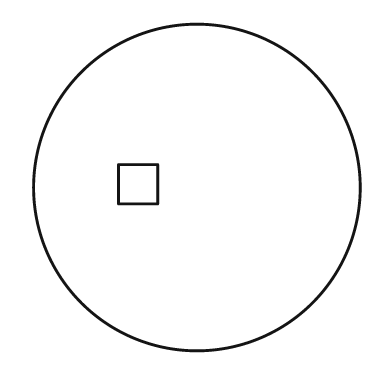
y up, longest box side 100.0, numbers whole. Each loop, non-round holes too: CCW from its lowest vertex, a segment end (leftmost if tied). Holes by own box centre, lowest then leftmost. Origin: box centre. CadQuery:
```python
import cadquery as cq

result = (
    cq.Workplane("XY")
    .moveTo(0.0, 0.0)
    .circle(50.0)
    .moveTo(-24.0, -5.0)
    .lineTo(-12.0, -5.0)
    .lineTo(-12.0, 7.0)
    .lineTo(-24.0, 7.0)
    .close()
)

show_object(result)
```